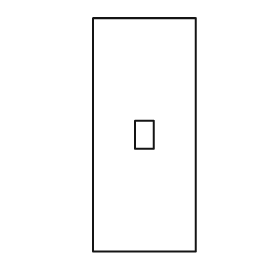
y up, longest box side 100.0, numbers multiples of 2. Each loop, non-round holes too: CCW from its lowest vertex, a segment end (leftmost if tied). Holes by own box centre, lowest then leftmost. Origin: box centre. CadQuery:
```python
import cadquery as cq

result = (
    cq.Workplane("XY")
    .moveTo(-22.0, -50.0)
    .lineTo(22.0, -50.0)
    .lineTo(22.0, 50.0)
    .lineTo(-22.0, 50.0)
    .close()
    .moveTo(-4.0, -6.0)
    .lineTo(4.0, -6.0)
    .lineTo(4.0, 6.0)
    .lineTo(-4.0, 6.0)
    .close()
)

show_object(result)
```